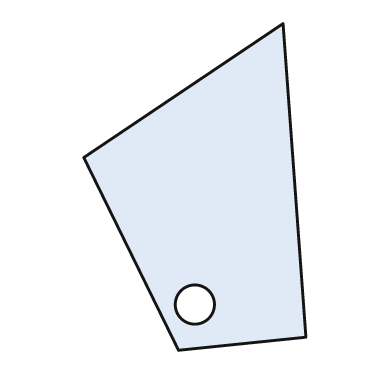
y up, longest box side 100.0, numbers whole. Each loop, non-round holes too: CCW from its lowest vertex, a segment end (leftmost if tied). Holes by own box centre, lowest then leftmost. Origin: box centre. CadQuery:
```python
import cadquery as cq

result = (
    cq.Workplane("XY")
    .moveTo(-5.0, -50.0)
    .lineTo(34.0, -46.0)
    .lineTo(27.0, 50.0)
    .lineTo(-34.0, 9.0)
    .close()
    .moveTo(0.0, -36.0)
    .circle(6.0)
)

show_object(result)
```